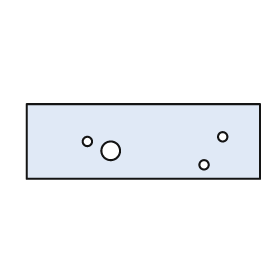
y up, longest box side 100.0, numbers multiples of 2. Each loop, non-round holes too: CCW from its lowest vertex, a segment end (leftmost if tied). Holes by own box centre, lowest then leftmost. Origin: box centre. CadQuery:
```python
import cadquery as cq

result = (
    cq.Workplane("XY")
    .moveTo(-50.0, -16.0)
    .lineTo(50.0, -16.0)
    .lineTo(50.0, 16.0)
    .lineTo(-50.0, 16.0)
    .close()
    .moveTo(26.0, -10.0)
    .circle(2.0)
    .moveTo(-14.0, -4.0)
    .circle(4.0)
    .moveTo(-24.0, 0.0)
    .circle(2.0)
    .moveTo(34.0, 2.0)
    .circle(2.0)
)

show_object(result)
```